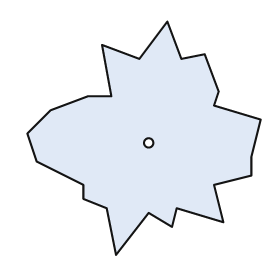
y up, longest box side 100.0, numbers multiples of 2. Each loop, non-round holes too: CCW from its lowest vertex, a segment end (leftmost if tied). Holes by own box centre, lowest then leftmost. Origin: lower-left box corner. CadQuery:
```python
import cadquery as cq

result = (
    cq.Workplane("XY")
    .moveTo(38.0, 0.0)
    .lineTo(52.0, 18.0)
    .lineTo(62.0, 12.0)
    .lineTo(64.0, 20.0)
    .lineTo(84.0, 14.0)
    .lineTo(80.0, 30.0)
    .lineTo(96.0, 34.0)
    .lineTo(96.0, 42.0)
    .lineTo(100.0, 58.0)
    .lineTo(80.0, 64.0)
    .lineTo(82.0, 70.0)
    .lineTo(76.0, 86.0)
    .lineTo(66.0, 84.0)
    .lineTo(60.0, 100.0)
    .lineTo(48.0, 84.0)
    .lineTo(32.0, 90.0)
    .lineTo(36.0, 68.0)
    .lineTo(26.0, 68.0)
    .lineTo(10.0, 62.0)
    .lineTo(0.0, 52.0)
    .lineTo(4.0, 40.0)
    .lineTo(24.0, 30.0)
    .lineTo(24.0, 24.0)
    .lineTo(34.0, 20.0)
    .close()
    .moveTo(52.0, 48.0)
    .circle(2.0)
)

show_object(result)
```